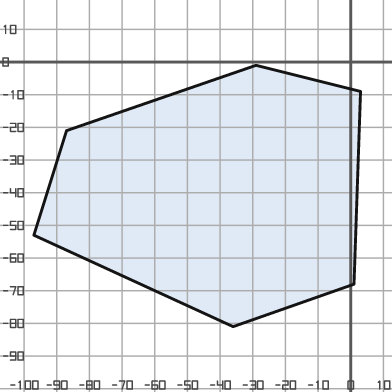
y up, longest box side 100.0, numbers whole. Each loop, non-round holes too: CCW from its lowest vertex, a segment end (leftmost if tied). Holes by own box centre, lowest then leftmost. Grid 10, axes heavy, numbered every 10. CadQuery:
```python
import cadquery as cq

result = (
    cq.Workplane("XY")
    .moveTo(-36.0, -81.0)
    .lineTo(1.0, -68.0)
    .lineTo(3.0, -9.0)
    .lineTo(-29.0, -1.0)
    .lineTo(-87.0, -21.0)
    .lineTo(-97.0, -53.0)
    .close()
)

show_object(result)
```